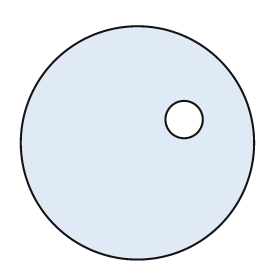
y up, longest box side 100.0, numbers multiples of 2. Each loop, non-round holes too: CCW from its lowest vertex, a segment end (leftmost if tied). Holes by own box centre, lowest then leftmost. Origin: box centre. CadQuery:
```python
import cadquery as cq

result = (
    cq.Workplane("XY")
    .moveTo(0.0, 0.0)
    .circle(50.0)
    .moveTo(20.0, 10.0)
    .circle(8.0)
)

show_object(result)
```